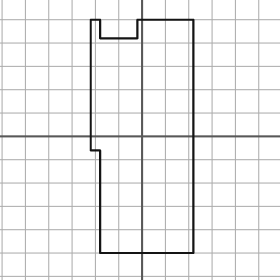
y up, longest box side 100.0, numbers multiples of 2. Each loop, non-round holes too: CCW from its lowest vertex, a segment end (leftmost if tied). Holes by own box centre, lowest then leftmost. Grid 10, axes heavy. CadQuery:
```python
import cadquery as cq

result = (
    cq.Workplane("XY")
    .moveTo(-18.0, -50.0)
    .lineTo(22.0, -50.0)
    .lineTo(22.0, 50.0)
    .lineTo(-2.0, 50.0)
    .lineTo(-2.0, 42.0)
    .lineTo(-18.0, 42.0)
    .lineTo(-18.0, 50.0)
    .lineTo(-22.0, 50.0)
    .lineTo(-22.0, -6.0)
    .lineTo(-18.0, -6.0)
    .close()
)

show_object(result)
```